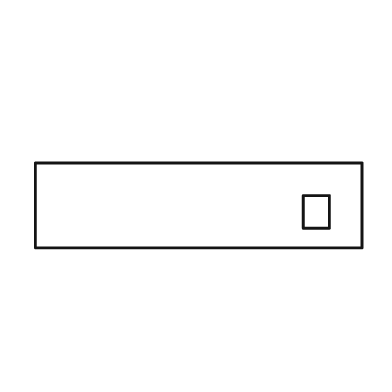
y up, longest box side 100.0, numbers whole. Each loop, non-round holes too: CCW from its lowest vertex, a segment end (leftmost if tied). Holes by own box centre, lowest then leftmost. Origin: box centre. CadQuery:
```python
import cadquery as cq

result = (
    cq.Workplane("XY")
    .moveTo(-50.0, -13.0)
    .lineTo(50.0, -13.0)
    .lineTo(50.0, 13.0)
    .lineTo(-50.0, 13.0)
    .close()
    .moveTo(32.0, -7.0)
    .lineTo(40.0, -7.0)
    .lineTo(40.0, 3.0)
    .lineTo(32.0, 3.0)
    .close()
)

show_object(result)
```